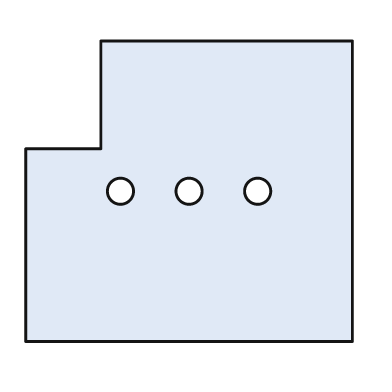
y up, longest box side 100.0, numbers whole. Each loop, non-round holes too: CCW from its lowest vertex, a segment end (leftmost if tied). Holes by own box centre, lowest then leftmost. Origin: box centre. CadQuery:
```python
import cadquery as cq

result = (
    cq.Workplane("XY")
    .moveTo(-50.0, -46.0)
    .lineTo(50.0, -46.0)
    .lineTo(50.0, 46.0)
    .lineTo(-27.0, 46.0)
    .lineTo(-27.0, 13.0)
    .lineTo(-50.0, 13.0)
    .close()
    .moveTo(-21.0, 0.0)
    .circle(4.0)
    .moveTo(0.0, 0.0)
    .circle(4.0)
    .moveTo(21.0, 0.0)
    .circle(4.0)
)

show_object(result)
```